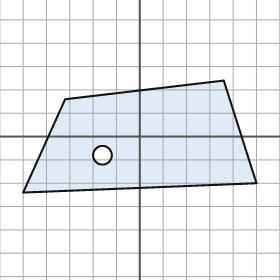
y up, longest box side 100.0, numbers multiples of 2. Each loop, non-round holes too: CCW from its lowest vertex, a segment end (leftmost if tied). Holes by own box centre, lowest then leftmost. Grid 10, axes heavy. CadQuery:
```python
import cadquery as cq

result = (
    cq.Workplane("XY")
    .moveTo(-50.0, -24.0)
    .lineTo(50.0, -20.0)
    .lineTo(36.0, 24.0)
    .lineTo(-32.0, 16.0)
    .close()
    .moveTo(-16.0, -8.0)
    .circle(4.0)
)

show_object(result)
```